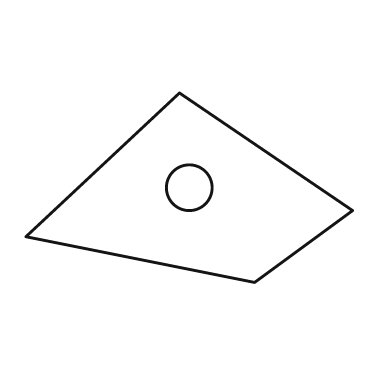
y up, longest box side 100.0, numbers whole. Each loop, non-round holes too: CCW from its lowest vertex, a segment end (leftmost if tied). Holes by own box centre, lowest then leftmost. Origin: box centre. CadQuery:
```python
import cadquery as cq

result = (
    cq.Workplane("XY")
    .moveTo(20.0, -29.0)
    .lineTo(50.0, -7.0)
    .lineTo(-3.0, 29.0)
    .lineTo(-50.0, -15.0)
    .close()
    .moveTo(0.0, 0.0)
    .circle(7.0)
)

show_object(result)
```